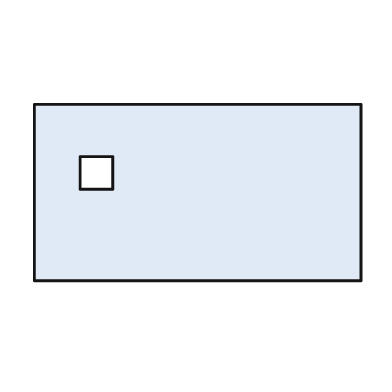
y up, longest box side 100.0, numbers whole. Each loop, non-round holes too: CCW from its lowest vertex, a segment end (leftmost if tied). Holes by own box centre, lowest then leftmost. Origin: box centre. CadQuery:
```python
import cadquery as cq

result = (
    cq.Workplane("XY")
    .moveTo(-50.0, -27.0)
    .lineTo(50.0, -27.0)
    .lineTo(50.0, 27.0)
    .lineTo(-50.0, 27.0)
    .close()
    .moveTo(-36.0, 1.0)
    .lineTo(-26.0, 1.0)
    .lineTo(-26.0, 11.0)
    .lineTo(-36.0, 11.0)
    .close()
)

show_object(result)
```